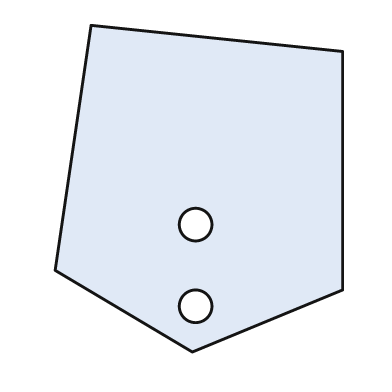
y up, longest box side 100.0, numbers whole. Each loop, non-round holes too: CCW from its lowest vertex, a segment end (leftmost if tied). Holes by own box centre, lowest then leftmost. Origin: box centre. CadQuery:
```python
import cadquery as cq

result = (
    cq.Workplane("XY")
    .moveTo(-2.0, -50.0)
    .lineTo(44.0, -31.0)
    .lineTo(44.0, 42.0)
    .lineTo(-33.0, 50.0)
    .lineTo(-44.0, -25.0)
    .close()
    .moveTo(-1.0, -36.0)
    .circle(5.0)
    .moveTo(-1.0, -11.0)
    .circle(5.0)
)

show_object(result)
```